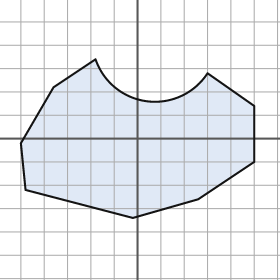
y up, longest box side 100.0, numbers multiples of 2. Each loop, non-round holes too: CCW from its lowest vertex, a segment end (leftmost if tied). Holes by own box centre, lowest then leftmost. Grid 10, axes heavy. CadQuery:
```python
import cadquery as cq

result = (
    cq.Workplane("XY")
    .moveTo(-2.0, -34.0)
    .lineTo(26.0, -26.0)
    .lineTo(50.0, -10.0)
    .lineTo(50.0, 14.0)
    .lineTo(30.0, 28.0)
    .threePointArc((4.0, 16.0), (-18.0, 34.0))
    .lineTo(-36.0, 22.0)
    .lineTo(-50.0, -2.0)
    .lineTo(-48.0, -22.0)
    .close()
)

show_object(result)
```